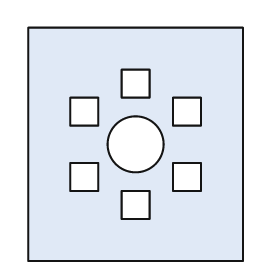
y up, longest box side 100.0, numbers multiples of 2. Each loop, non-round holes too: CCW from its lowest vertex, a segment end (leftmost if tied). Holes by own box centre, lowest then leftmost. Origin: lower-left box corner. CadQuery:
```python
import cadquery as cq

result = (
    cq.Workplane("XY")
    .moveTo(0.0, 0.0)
    .lineTo(92.0, 0.0)
    .lineTo(92.0, 100.0)
    .lineTo(0.0, 100.0)
    .close()
    .moveTo(40.0, 18.0)
    .lineTo(52.0, 18.0)
    .lineTo(52.0, 30.0)
    .lineTo(40.0, 30.0)
    .close()
    .moveTo(18.0, 30.0)
    .lineTo(30.0, 30.0)
    .lineTo(30.0, 42.0)
    .lineTo(18.0, 42.0)
    .close()
    .moveTo(62.0, 30.0)
    .lineTo(74.0, 30.0)
    .lineTo(74.0, 42.0)
    .lineTo(62.0, 42.0)
    .close()
    .moveTo(46.0, 50.0)
    .circle(12.0)
    .moveTo(18.0, 58.0)
    .lineTo(30.0, 58.0)
    .lineTo(30.0, 70.0)
    .lineTo(18.0, 70.0)
    .close()
    .moveTo(62.0, 58.0)
    .lineTo(74.0, 58.0)
    .lineTo(74.0, 70.0)
    .lineTo(62.0, 70.0)
    .close()
    .moveTo(40.0, 70.0)
    .lineTo(52.0, 70.0)
    .lineTo(52.0, 82.0)
    .lineTo(40.0, 82.0)
    .close()
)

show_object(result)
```